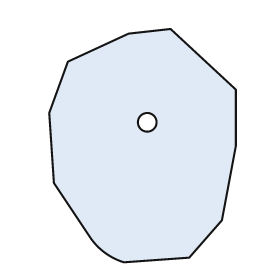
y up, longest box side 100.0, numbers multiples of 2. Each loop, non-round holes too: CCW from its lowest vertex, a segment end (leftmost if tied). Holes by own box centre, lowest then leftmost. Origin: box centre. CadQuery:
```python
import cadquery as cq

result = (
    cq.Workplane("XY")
    .moveTo(-8.0, -50.0)
    .lineTo(20.0, -48.0)
    .lineTo(34.0, -32.0)
    .lineTo(40.0, 0.0)
    .lineTo(40.0, 24.0)
    .lineTo(12.0, 50.0)
    .lineTo(-6.0, 48.0)
    .lineTo(-32.0, 36.0)
    .lineTo(-40.0, 14.0)
    .lineTo(-38.0, -16.0)
    .lineTo(-22.0, -40.0)
    .threePointArc((-16.0, -46.0), (-8.0, -50.0))
    .close()
    .moveTo(2.0, 10.0)
    .circle(4.0)
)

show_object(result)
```